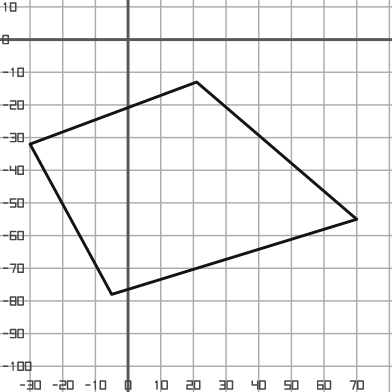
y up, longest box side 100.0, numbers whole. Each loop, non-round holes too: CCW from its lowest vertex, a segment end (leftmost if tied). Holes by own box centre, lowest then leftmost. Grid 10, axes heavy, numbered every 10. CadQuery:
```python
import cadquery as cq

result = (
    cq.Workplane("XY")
    .moveTo(-5.0, -78.0)
    .lineTo(70.0, -55.0)
    .lineTo(21.0, -13.0)
    .lineTo(-30.0, -32.0)
    .close()
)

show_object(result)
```